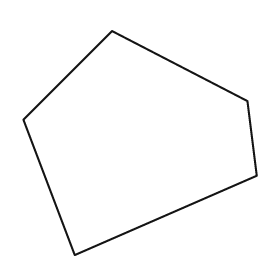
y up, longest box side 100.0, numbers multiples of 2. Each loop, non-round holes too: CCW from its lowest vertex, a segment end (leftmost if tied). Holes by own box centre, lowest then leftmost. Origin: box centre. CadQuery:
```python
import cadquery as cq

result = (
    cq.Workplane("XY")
    .moveTo(-28.0, -48.0)
    .lineTo(50.0, -14.0)
    .lineTo(46.0, 18.0)
    .lineTo(-12.0, 48.0)
    .lineTo(-50.0, 10.0)
    .close()
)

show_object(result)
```